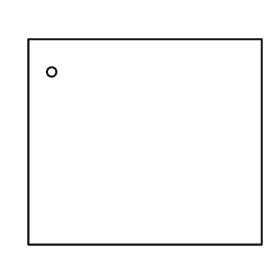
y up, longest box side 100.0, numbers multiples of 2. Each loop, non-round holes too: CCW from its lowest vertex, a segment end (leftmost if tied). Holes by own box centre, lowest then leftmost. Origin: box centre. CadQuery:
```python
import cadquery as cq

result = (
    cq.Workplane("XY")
    .moveTo(-50.0, -44.0)
    .lineTo(50.0, -44.0)
    .lineTo(50.0, 44.0)
    .lineTo(-50.0, 44.0)
    .close()
    .moveTo(-40.0, 30.0)
    .circle(2.0)
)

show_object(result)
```